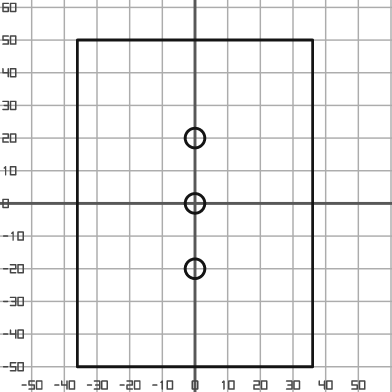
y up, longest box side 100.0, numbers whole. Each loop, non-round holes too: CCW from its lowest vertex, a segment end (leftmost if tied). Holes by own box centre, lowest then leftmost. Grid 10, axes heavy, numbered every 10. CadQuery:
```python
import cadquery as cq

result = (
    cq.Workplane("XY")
    .moveTo(-36.0, -50.0)
    .lineTo(36.0, -50.0)
    .lineTo(36.0, 50.0)
    .lineTo(-36.0, 50.0)
    .close()
    .moveTo(0.0, -20.0)
    .circle(3.0)
    .moveTo(0.0, 0.0)
    .circle(3.0)
    .moveTo(0.0, 20.0)
    .circle(3.0)
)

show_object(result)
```